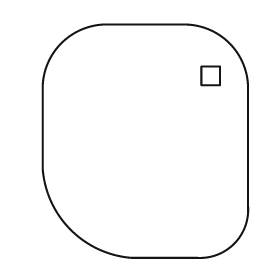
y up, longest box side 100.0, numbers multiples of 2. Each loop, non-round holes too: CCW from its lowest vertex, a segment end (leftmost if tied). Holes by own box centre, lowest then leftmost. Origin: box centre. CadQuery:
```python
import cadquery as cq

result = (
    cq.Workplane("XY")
    .moveTo(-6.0, -50.0)
    .lineTo(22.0, -50.0)
    .threePointArc((38.0, -44.0), (44.0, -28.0))
    .lineTo(44.0, 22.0)
    .threePointArc((36.0, 42.0), (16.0, 50.0))
    .lineTo(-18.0, 50.0)
    .threePointArc((-36.0, 42.0), (-44.0, 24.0))
    .lineTo(-44.0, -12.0)
    .threePointArc((-32.0, -38.0), (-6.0, -50.0))
    .close()
    .moveTo(24.0, 24.0)
    .lineTo(32.0, 24.0)
    .lineTo(32.0, 32.0)
    .lineTo(24.0, 32.0)
    .close()
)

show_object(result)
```